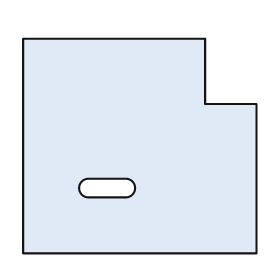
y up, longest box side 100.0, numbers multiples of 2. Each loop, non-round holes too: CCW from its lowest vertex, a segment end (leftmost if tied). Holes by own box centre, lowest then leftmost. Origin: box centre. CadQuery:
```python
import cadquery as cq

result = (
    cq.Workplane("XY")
    .moveTo(-50.0, -46.0)
    .lineTo(50.0, -46.0)
    .lineTo(50.0, 18.0)
    .lineTo(28.0, 18.0)
    .lineTo(28.0, 46.0)
    .lineTo(-50.0, 46.0)
    .close()
    .moveTo(-22.0, -22.0)
    .lineTo(-6.0, -22.0)
    .threePointArc((-2.0, -18.0), (-6.0, -14.0))
    .lineTo(-22.0, -14.0)
    .threePointArc((-26.0, -18.0), (-22.0, -22.0))
    .close()
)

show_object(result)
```